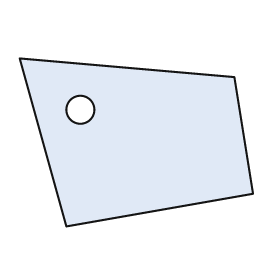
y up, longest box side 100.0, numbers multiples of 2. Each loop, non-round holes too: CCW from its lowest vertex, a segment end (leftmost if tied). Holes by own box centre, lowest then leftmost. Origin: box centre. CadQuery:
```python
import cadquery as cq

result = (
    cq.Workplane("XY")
    .moveTo(-30.0, -36.0)
    .lineTo(50.0, -22.0)
    .lineTo(42.0, 28.0)
    .lineTo(-50.0, 36.0)
    .close()
    .moveTo(-24.0, 14.0)
    .circle(6.0)
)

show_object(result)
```